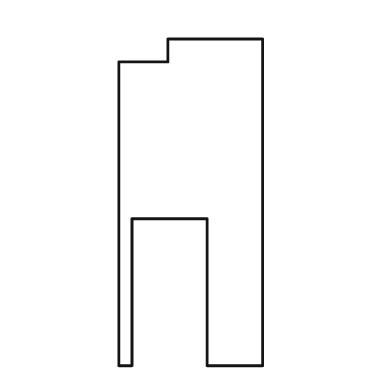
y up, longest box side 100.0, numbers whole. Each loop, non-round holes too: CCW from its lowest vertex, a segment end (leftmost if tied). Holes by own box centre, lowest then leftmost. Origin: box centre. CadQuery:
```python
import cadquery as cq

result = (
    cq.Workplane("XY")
    .moveTo(-22.0, -50.0)
    .lineTo(-18.0, -50.0)
    .lineTo(-18.0, -5.0)
    .lineTo(5.0, -5.0)
    .lineTo(5.0, -50.0)
    .lineTo(22.0, -50.0)
    .lineTo(22.0, 50.0)
    .lineTo(-7.0, 50.0)
    .lineTo(-7.0, 43.0)
    .lineTo(-22.0, 43.0)
    .close()
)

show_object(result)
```